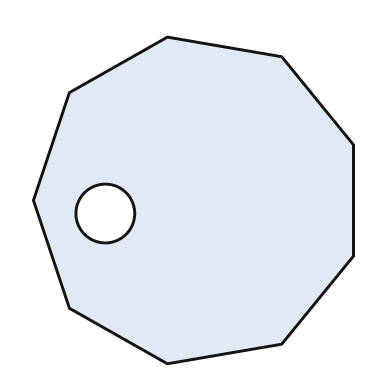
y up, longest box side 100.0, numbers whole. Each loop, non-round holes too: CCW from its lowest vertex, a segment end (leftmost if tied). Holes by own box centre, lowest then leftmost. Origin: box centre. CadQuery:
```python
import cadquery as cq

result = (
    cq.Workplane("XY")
    .moveTo(-8.0, -50.0)
    .lineTo(27.0, -44.0)
    .lineTo(49.0, -17.0)
    .lineTo(49.0, 17.0)
    .lineTo(27.0, 44.0)
    .lineTo(-8.0, 50.0)
    .lineTo(-38.0, 33.0)
    .lineTo(-49.0, 0.0)
    .lineTo(-38.0, -33.0)
    .close()
    .moveTo(-27.0, -4.0)
    .circle(9.0)
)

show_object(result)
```